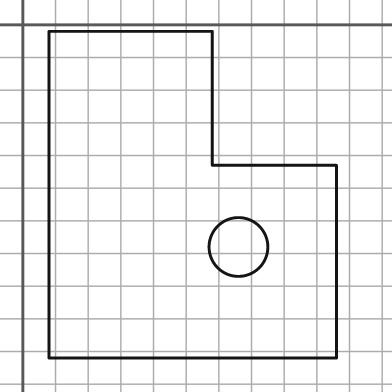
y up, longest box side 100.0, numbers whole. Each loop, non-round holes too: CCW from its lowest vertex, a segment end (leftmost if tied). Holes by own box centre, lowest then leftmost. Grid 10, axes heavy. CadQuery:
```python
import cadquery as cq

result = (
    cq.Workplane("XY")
    .moveTo(8.0, -102.0)
    .lineTo(96.0, -102.0)
    .lineTo(96.0, -43.0)
    .lineTo(58.0, -43.0)
    .lineTo(58.0, -2.0)
    .lineTo(8.0, -2.0)
    .close()
    .moveTo(66.0, -68.0)
    .circle(9.0)
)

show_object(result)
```